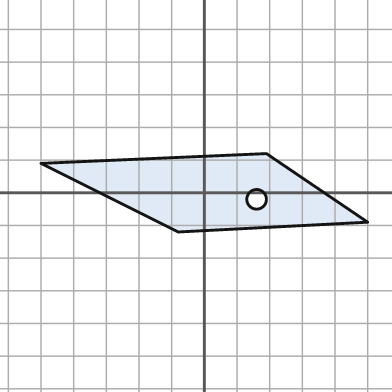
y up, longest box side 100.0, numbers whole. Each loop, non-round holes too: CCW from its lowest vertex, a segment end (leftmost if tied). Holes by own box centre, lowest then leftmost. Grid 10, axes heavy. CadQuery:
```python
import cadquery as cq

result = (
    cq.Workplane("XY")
    .moveTo(-8.0, -12.0)
    .lineTo(50.0, -9.0)
    .lineTo(19.0, 12.0)
    .lineTo(-50.0, 9.0)
    .close()
    .moveTo(16.0, -2.0)
    .circle(3.0)
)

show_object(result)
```